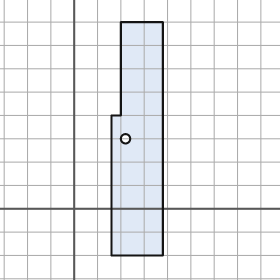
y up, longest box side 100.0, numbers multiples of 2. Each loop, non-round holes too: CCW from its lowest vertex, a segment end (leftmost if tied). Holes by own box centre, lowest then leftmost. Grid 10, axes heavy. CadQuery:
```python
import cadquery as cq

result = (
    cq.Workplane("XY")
    .moveTo(16.0, -20.0)
    .lineTo(38.0, -20.0)
    .lineTo(38.0, 80.0)
    .lineTo(20.0, 80.0)
    .lineTo(20.0, 40.0)
    .lineTo(16.0, 40.0)
    .close()
    .moveTo(22.0, 30.0)
    .circle(2.0)
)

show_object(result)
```